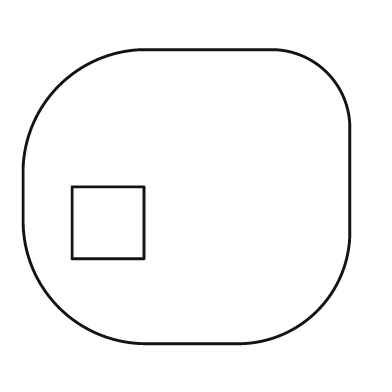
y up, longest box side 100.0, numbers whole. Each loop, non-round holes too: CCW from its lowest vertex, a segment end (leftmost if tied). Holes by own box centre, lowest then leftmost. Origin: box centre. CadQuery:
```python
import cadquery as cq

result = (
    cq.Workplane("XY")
    .moveTo(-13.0, -45.0)
    .lineTo(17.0, -45.0)
    .threePointArc((40.0, -35.0), (50.0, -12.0))
    .lineTo(50.0, 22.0)
    .threePointArc((43.0, 38.0), (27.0, 45.0))
    .lineTo(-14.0, 45.0)
    .threePointArc((-39.0, 34.0), (-50.0, 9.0))
    .lineTo(-50.0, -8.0)
    .threePointArc((-39.0, -34.0), (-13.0, -45.0))
    .close()
    .moveTo(-35.0, -19.0)
    .lineTo(-13.0, -19.0)
    .lineTo(-13.0, 3.0)
    .lineTo(-35.0, 3.0)
    .close()
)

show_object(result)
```